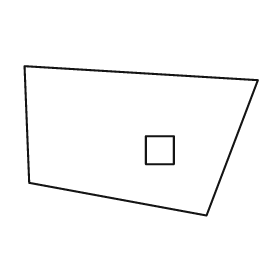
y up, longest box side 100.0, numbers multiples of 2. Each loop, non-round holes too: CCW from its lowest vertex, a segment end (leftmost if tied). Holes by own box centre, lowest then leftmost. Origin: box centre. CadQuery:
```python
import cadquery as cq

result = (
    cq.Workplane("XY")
    .moveTo(28.0, -32.0)
    .lineTo(50.0, 26.0)
    .lineTo(-50.0, 32.0)
    .lineTo(-48.0, -18.0)
    .close()
    .moveTo(2.0, -10.0)
    .lineTo(14.0, -10.0)
    .lineTo(14.0, 2.0)
    .lineTo(2.0, 2.0)
    .close()
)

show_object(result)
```